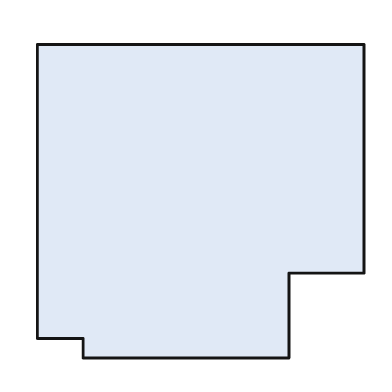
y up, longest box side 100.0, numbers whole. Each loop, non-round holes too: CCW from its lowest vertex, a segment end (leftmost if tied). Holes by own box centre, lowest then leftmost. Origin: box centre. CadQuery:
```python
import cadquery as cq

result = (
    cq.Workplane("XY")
    .moveTo(-36.0, -48.0)
    .lineTo(27.0, -48.0)
    .lineTo(27.0, -22.0)
    .lineTo(50.0, -22.0)
    .lineTo(50.0, 48.0)
    .lineTo(-50.0, 48.0)
    .lineTo(-50.0, -42.0)
    .lineTo(-36.0, -42.0)
    .close()
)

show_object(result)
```